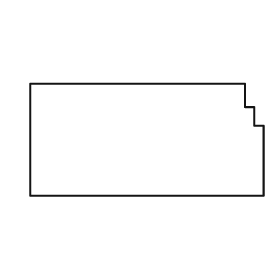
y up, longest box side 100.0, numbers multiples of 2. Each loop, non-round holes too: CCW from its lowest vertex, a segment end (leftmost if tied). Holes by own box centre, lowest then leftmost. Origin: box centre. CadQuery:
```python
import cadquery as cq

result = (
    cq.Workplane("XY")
    .moveTo(-50.0, -24.0)
    .lineTo(50.0, -24.0)
    .lineTo(50.0, 6.0)
    .lineTo(46.0, 6.0)
    .lineTo(46.0, 14.0)
    .lineTo(42.0, 14.0)
    .lineTo(42.0, 24.0)
    .lineTo(-50.0, 24.0)
    .close()
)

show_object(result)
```